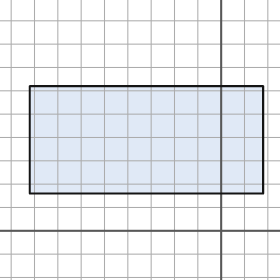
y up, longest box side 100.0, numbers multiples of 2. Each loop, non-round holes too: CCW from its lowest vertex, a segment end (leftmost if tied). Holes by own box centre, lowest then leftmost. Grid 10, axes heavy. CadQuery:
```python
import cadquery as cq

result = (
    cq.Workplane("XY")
    .moveTo(-82.0, 16.0)
    .lineTo(18.0, 16.0)
    .lineTo(18.0, 62.0)
    .lineTo(-82.0, 62.0)
    .close()
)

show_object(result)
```